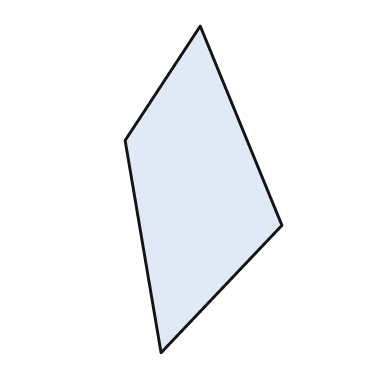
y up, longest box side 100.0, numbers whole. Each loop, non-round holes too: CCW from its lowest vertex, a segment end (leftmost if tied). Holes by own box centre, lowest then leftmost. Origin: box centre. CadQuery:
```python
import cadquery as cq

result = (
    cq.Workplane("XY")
    .moveTo(-13.0, -50.0)
    .lineTo(24.0, -11.0)
    .lineTo(-1.0, 50.0)
    .lineTo(-24.0, 15.0)
    .close()
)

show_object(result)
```